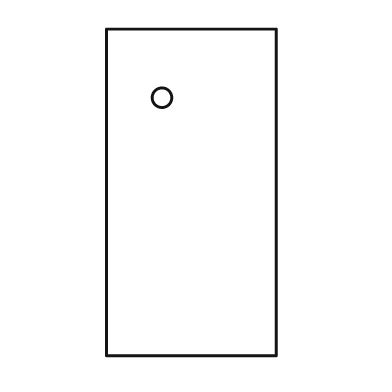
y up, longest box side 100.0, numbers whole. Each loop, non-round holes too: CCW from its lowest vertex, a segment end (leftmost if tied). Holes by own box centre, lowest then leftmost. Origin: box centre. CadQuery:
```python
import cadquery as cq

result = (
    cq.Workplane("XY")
    .moveTo(-26.0, -50.0)
    .lineTo(26.0, -50.0)
    .lineTo(26.0, 50.0)
    .lineTo(-26.0, 50.0)
    .close()
    .moveTo(-9.0, 29.0)
    .circle(3.0)
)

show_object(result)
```